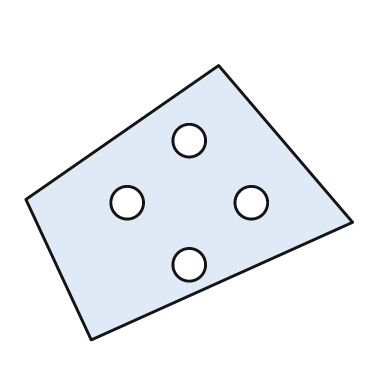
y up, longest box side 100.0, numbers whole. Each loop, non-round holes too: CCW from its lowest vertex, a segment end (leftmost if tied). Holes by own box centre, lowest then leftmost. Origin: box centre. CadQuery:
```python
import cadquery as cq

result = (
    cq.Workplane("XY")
    .moveTo(-30.0, -42.0)
    .lineTo(50.0, -6.0)
    .lineTo(9.0, 42.0)
    .lineTo(-50.0, 1.0)
    .close()
    .moveTo(0.0, -19.0)
    .circle(5.0)
    .moveTo(-19.0, 0.0)
    .circle(5.0)
    .moveTo(19.0, 0.0)
    .circle(5.0)
    .moveTo(0.0, 19.0)
    .circle(5.0)
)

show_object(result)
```